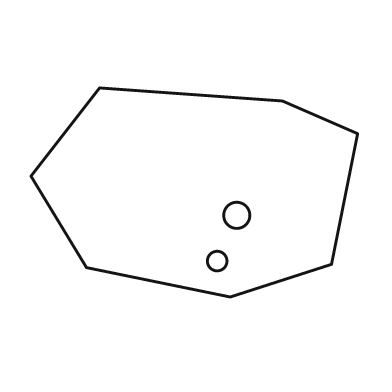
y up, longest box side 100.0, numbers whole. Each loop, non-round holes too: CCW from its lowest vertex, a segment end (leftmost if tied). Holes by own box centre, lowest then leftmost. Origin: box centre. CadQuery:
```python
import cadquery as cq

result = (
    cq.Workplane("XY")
    .moveTo(11.0, -32.0)
    .lineTo(42.0, -22.0)
    .lineTo(50.0, 18.0)
    .lineTo(27.0, 28.0)
    .lineTo(-29.0, 32.0)
    .lineTo(-50.0, 5.0)
    .lineTo(-33.0, -23.0)
    .close()
    .moveTo(7.0, -21.0)
    .circle(3.0)
    .moveTo(13.0, -7.0)
    .circle(4.0)
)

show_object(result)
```